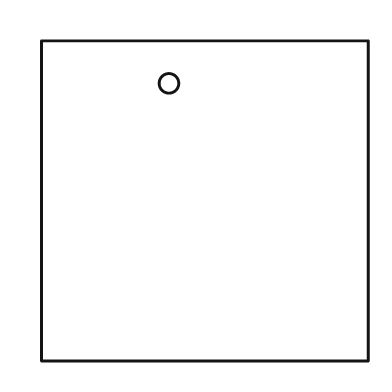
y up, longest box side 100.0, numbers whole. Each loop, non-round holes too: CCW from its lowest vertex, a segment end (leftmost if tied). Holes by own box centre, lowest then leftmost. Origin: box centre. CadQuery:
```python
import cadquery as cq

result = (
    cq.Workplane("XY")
    .moveTo(-50.0, -49.0)
    .lineTo(50.0, -49.0)
    .lineTo(50.0, 49.0)
    .lineTo(-50.0, 49.0)
    .close()
    .moveTo(-11.0, 36.0)
    .circle(3.0)
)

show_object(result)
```